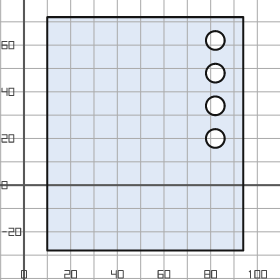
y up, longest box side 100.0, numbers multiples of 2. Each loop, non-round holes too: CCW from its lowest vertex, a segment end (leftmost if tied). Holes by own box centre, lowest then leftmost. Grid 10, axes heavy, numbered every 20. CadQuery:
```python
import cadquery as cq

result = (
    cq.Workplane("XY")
    .moveTo(10.0, -28.0)
    .lineTo(94.0, -28.0)
    .lineTo(94.0, 72.0)
    .lineTo(10.0, 72.0)
    .close()
    .moveTo(82.0, 20.0)
    .circle(4.0)
    .moveTo(82.0, 34.0)
    .circle(4.0)
    .moveTo(82.0, 48.0)
    .circle(4.0)
    .moveTo(82.0, 62.0)
    .circle(4.0)
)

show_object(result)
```